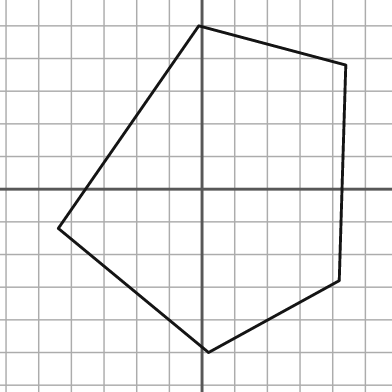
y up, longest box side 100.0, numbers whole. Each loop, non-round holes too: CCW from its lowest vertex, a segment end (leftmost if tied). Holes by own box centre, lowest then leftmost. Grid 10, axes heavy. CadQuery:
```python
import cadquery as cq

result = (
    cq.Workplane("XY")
    .moveTo(2.0, -50.0)
    .lineTo(42.0, -28.0)
    .lineTo(44.0, 38.0)
    .lineTo(-1.0, 50.0)
    .lineTo(-44.0, -12.0)
    .close()
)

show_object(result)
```